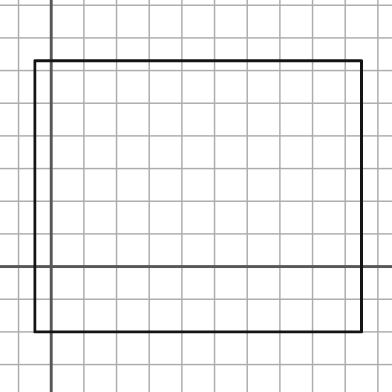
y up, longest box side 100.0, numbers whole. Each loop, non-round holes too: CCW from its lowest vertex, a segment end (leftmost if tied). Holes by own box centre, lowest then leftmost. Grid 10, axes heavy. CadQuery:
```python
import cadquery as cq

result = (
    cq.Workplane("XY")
    .moveTo(-5.0, -20.0)
    .lineTo(95.0, -20.0)
    .lineTo(95.0, 63.0)
    .lineTo(-5.0, 63.0)
    .close()
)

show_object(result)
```